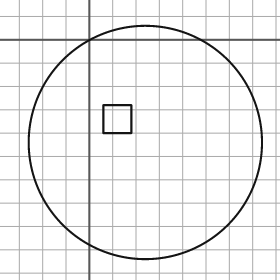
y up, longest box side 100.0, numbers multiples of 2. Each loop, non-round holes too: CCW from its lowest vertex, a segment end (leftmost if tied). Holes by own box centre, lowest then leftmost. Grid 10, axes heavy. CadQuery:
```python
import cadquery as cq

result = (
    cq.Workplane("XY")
    .moveTo(24.0, -44.0)
    .circle(50.0)
    .moveTo(6.0, -40.0)
    .lineTo(18.0, -40.0)
    .lineTo(18.0, -28.0)
    .lineTo(6.0, -28.0)
    .close()
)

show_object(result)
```